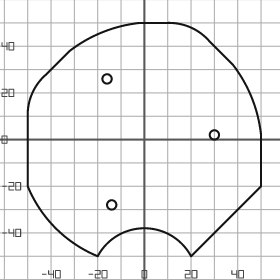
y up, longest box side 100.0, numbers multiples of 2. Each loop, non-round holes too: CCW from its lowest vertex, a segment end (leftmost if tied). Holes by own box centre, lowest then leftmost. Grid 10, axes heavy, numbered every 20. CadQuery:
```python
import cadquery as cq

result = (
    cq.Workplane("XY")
    .moveTo(-20.0, -50.0)
    .threePointArc((0.0, -38.0), (20.0, -50.0))
    .lineTo(50.0, -20.0)
    .lineTo(50.0, 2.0)
    .threePointArc((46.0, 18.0), (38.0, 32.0))
    .lineTo(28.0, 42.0)
    .threePointArc((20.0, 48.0), (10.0, 50.0))
    .lineTo(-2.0, 50.0)
    .threePointArc((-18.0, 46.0), (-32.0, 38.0))
    .lineTo(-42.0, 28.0)
    .threePointArc((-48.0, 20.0), (-50.0, 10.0))
    .lineTo(-50.0, -20.0)
    .threePointArc((-38.0, -38.0), (-20.0, -50.0))
    .close()
    .moveTo(-14.0, -28.0)
    .circle(2.0)
    .moveTo(30.0, 2.0)
    .circle(2.0)
    .moveTo(-16.0, 26.0)
    .circle(2.0)
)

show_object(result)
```